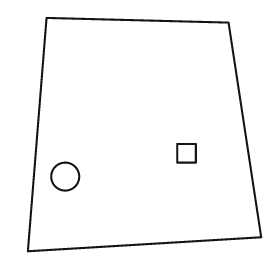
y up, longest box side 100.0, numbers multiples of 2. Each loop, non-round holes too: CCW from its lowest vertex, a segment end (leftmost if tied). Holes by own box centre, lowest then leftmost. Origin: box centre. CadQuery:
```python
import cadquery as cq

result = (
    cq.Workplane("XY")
    .moveTo(-50.0, -50.0)
    .lineTo(50.0, -44.0)
    .lineTo(36.0, 48.0)
    .lineTo(-42.0, 50.0)
    .close()
    .moveTo(-34.0, -18.0)
    .circle(6.0)
    .moveTo(14.0, -12.0)
    .lineTo(22.0, -12.0)
    .lineTo(22.0, -4.0)
    .lineTo(14.0, -4.0)
    .close()
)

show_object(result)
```